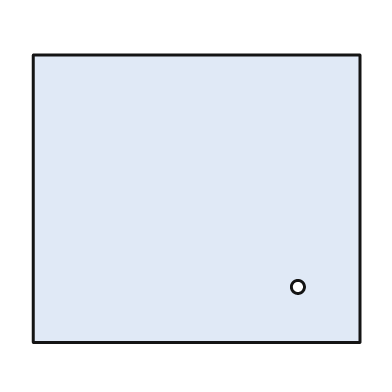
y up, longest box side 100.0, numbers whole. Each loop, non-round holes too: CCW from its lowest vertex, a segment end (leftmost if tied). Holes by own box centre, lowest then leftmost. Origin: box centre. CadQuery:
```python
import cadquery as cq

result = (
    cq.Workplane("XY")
    .moveTo(-50.0, -44.0)
    .lineTo(50.0, -44.0)
    .lineTo(50.0, 44.0)
    .lineTo(-50.0, 44.0)
    .close()
    .moveTo(31.0, -27.0)
    .circle(2.0)
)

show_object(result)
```